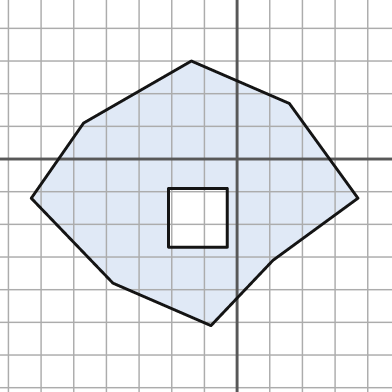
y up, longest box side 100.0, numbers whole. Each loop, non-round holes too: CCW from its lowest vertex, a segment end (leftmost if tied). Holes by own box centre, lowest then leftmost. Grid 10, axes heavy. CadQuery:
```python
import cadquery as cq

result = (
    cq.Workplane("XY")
    .moveTo(-8.0, -51.0)
    .lineTo(11.0, -31.0)
    .lineTo(37.0, -12.0)
    .lineTo(16.0, 17.0)
    .lineTo(-14.0, 30.0)
    .lineTo(-47.0, 11.0)
    .lineTo(-63.0, -12.0)
    .lineTo(-38.0, -38.0)
    .close()
    .moveTo(-21.0, -27.0)
    .lineTo(-3.0, -27.0)
    .lineTo(-3.0, -9.0)
    .lineTo(-21.0, -9.0)
    .close()
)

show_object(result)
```